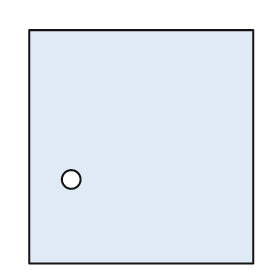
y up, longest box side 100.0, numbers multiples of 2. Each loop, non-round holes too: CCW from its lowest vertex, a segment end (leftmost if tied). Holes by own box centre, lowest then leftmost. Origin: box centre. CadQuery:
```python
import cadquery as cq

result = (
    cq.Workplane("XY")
    .moveTo(-48.0, -50.0)
    .lineTo(48.0, -50.0)
    .lineTo(48.0, 50.0)
    .lineTo(-48.0, 50.0)
    .close()
    .moveTo(-30.0, -14.0)
    .circle(4.0)
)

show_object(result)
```